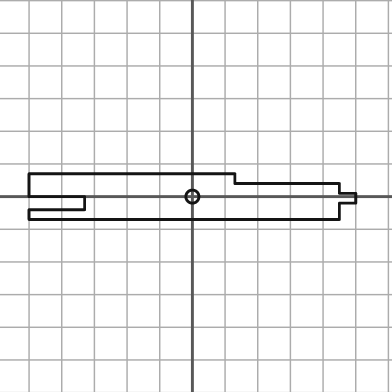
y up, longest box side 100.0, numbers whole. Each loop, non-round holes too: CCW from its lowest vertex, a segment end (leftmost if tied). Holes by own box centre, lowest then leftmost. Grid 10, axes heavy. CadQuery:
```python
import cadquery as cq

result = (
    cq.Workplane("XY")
    .moveTo(-50.0, -7.0)
    .lineTo(45.0, -7.0)
    .lineTo(45.0, -2.0)
    .lineTo(50.0, -2.0)
    .lineTo(50.0, 1.0)
    .lineTo(45.0, 1.0)
    .lineTo(45.0, 4.0)
    .lineTo(13.0, 4.0)
    .lineTo(13.0, 7.0)
    .lineTo(-50.0, 7.0)
    .lineTo(-50.0, 0.0)
    .lineTo(-33.0, 0.0)
    .lineTo(-33.0, -4.0)
    .lineTo(-50.0, -4.0)
    .close()
    .moveTo(0.0, 0.0)
    .circle(2.0)
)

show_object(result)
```